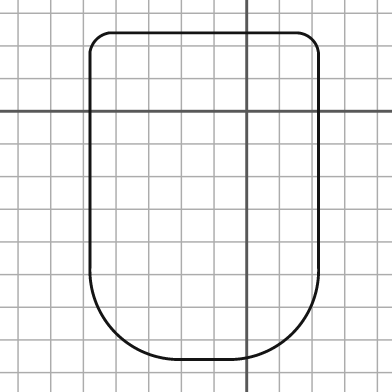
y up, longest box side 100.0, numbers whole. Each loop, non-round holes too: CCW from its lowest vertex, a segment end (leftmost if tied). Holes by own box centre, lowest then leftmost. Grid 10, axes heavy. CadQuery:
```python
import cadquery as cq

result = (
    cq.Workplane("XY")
    .moveTo(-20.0, -76.0)
    .lineTo(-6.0, -76.0)
    .threePointArc((14.0, -68.0), (22.0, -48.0))
    .lineTo(22.0, 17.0)
    .threePointArc((20.0, 22.0), (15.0, 24.0))
    .lineTo(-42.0, 24.0)
    .threePointArc((-46.0, 22.0), (-48.0, 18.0))
    .lineTo(-48.0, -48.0)
    .threePointArc((-40.0, -68.0), (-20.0, -76.0))
    .close()
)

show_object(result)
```